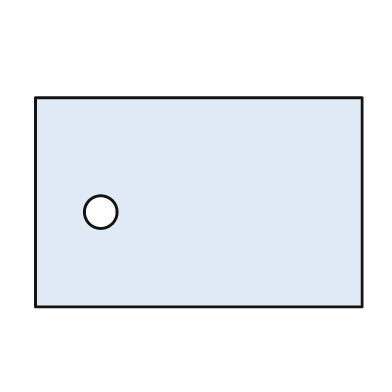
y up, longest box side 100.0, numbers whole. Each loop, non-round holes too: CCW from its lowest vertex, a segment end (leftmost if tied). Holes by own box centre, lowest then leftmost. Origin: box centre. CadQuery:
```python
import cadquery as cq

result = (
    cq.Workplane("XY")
    .moveTo(-50.0, -32.0)
    .lineTo(50.0, -32.0)
    .lineTo(50.0, 32.0)
    .lineTo(-50.0, 32.0)
    .close()
    .moveTo(-30.0, -3.0)
    .circle(5.0)
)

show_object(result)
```